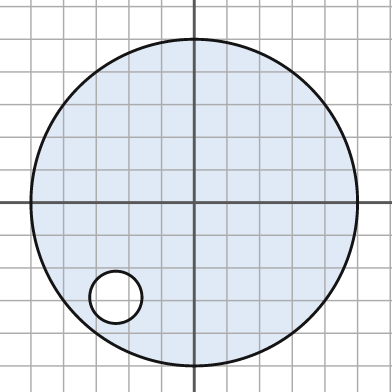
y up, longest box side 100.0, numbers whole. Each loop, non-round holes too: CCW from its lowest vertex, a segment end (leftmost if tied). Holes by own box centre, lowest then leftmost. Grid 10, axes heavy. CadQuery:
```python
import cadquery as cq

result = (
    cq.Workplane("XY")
    .moveTo(0.0, 0.0)
    .circle(50.0)
    .moveTo(-24.0, -29.0)
    .circle(8.0)
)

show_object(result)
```